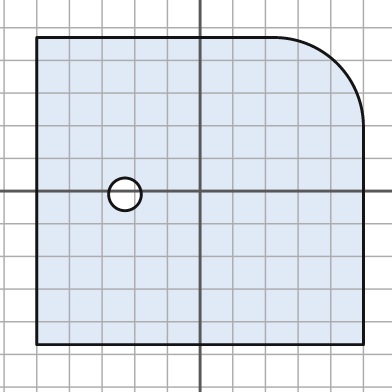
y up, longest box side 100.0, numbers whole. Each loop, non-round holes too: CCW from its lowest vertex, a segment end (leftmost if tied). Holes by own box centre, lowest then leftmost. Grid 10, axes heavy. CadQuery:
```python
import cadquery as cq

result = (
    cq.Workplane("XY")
    .moveTo(-50.0, -47.0)
    .lineTo(50.0, -47.0)
    .lineTo(50.0, 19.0)
    .threePointArc((42.0, 39.0), (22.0, 47.0))
    .lineTo(-50.0, 47.0)
    .close()
    .moveTo(-23.0, -1.0)
    .circle(5.0)
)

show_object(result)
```